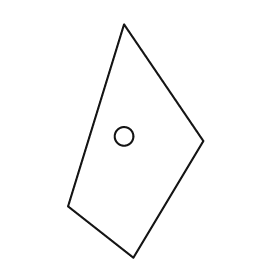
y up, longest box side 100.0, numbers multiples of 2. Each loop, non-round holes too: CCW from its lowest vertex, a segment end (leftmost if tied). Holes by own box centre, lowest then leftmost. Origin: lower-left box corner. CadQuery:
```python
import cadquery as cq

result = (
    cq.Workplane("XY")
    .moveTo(28.0, 0.0)
    .lineTo(58.0, 50.0)
    .lineTo(24.0, 100.0)
    .lineTo(0.0, 22.0)
    .close()
    .moveTo(24.0, 52.0)
    .circle(4.0)
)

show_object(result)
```